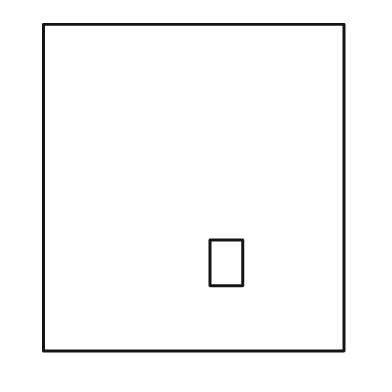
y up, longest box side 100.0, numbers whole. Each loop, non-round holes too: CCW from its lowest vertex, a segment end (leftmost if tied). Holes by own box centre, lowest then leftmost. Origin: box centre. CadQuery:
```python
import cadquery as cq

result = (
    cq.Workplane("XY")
    .moveTo(-46.0, -50.0)
    .lineTo(46.0, -50.0)
    .lineTo(46.0, 50.0)
    .lineTo(-46.0, 50.0)
    .close()
    .moveTo(5.0, -30.0)
    .lineTo(15.0, -30.0)
    .lineTo(15.0, -16.0)
    .lineTo(5.0, -16.0)
    .close()
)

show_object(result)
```